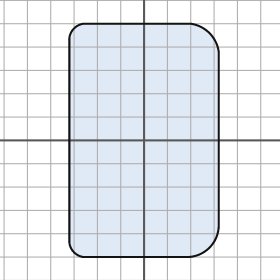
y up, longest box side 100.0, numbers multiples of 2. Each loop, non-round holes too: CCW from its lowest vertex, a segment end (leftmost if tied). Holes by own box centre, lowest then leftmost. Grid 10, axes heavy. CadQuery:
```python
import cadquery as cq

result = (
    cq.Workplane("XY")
    .moveTo(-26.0, -50.0)
    .lineTo(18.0, -50.0)
    .threePointArc((28.0, -46.0), (32.0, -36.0))
    .lineTo(32.0, 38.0)
    .threePointArc((28.0, 46.0), (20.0, 50.0))
    .lineTo(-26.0, 50.0)
    .threePointArc((-30.0, 48.0), (-32.0, 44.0))
    .lineTo(-32.0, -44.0)
    .threePointArc((-30.0, -48.0), (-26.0, -50.0))
    .close()
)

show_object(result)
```